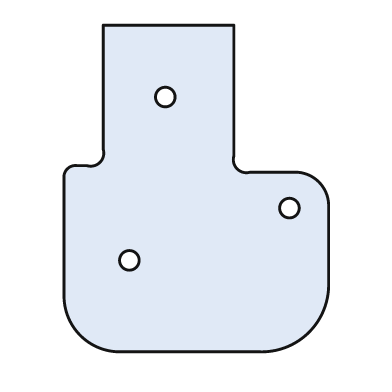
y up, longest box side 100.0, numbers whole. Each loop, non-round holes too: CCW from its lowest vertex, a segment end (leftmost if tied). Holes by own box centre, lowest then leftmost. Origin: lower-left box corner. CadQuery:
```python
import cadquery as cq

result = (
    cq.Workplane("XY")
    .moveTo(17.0, 0.0)
    .lineTo(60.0, 0.0)
    .threePointArc((75.0, 6.0), (81.0, 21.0))
    .lineTo(81.0, 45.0)
    .threePointArc((78.0, 52.0), (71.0, 55.0))
    .lineTo(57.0, 55.0)
    .threePointArc((53.0, 56.0), (52.0, 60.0))
    .lineTo(52.0, 100.0)
    .lineTo(12.0, 100.0)
    .lineTo(12.0, 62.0)
    .threePointArc((11.0, 58.0), (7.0, 57.0))
    .lineTo(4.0, 57.0)
    .threePointArc((1.0, 56.0), (0.0, 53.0))
    .lineTo(0.0, 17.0)
    .threePointArc((5.0, 5.0), (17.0, 0.0))
    .close()
    .moveTo(20.0, 28.0)
    .circle(3.0)
    .moveTo(69.0, 44.0)
    .circle(3.0)
    .moveTo(31.0, 78.0)
    .circle(3.0)
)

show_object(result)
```